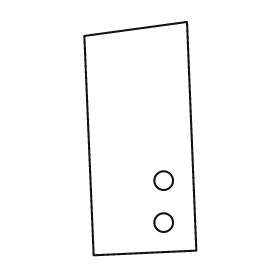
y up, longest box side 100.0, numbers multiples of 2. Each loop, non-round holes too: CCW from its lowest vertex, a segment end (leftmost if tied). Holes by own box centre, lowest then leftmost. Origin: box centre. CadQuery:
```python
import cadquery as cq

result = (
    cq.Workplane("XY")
    .moveTo(-20.0, -50.0)
    .lineTo(24.0, -48.0)
    .lineTo(20.0, 50.0)
    .lineTo(-24.0, 44.0)
    .close()
    .moveTo(10.0, -36.0)
    .circle(4.0)
    .moveTo(10.0, -18.0)
    .circle(4.0)
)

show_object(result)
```